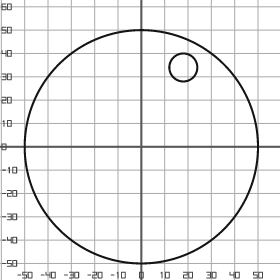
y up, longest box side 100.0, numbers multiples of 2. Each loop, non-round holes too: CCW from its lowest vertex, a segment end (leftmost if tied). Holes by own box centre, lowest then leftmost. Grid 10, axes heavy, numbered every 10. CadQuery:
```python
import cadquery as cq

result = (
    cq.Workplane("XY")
    .moveTo(0.0, 0.0)
    .circle(50.0)
    .moveTo(18.0, 34.0)
    .circle(6.0)
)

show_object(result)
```